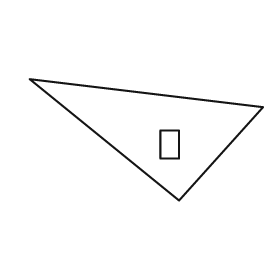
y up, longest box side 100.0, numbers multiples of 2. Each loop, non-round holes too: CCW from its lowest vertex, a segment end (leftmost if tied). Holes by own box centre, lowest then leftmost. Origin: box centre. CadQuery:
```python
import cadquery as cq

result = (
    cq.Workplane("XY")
    .moveTo(14.0, -26.0)
    .lineTo(50.0, 14.0)
    .lineTo(-50.0, 26.0)
    .close()
    .moveTo(6.0, -8.0)
    .lineTo(14.0, -8.0)
    .lineTo(14.0, 4.0)
    .lineTo(6.0, 4.0)
    .close()
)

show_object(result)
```